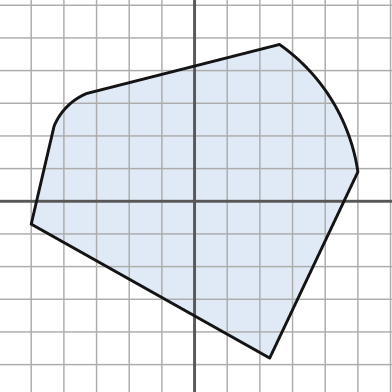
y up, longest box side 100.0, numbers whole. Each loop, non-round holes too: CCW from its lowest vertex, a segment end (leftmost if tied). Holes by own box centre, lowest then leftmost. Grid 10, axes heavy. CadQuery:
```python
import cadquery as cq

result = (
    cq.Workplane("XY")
    .moveTo(23.0, -48.0)
    .lineTo(50.0, 9.0)
    .threePointArc((42.0, 31.0), (26.0, 48.0))
    .lineTo(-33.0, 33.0)
    .threePointArc((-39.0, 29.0), (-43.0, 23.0))
    .lineTo(-50.0, -7.0)
    .close()
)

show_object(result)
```